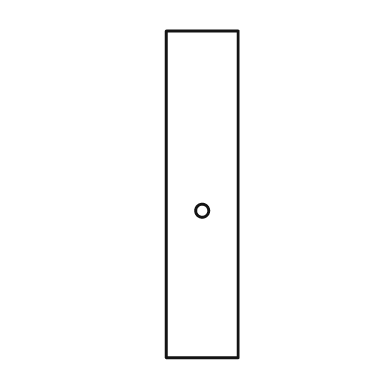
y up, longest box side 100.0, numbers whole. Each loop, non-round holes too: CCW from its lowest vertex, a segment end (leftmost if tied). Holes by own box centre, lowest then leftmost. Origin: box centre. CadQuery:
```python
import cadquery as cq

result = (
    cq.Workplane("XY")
    .moveTo(-11.0, -50.0)
    .lineTo(11.0, -50.0)
    .lineTo(11.0, 50.0)
    .lineTo(-11.0, 50.0)
    .close()
    .moveTo(0.0, -5.0)
    .circle(2.0)
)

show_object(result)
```